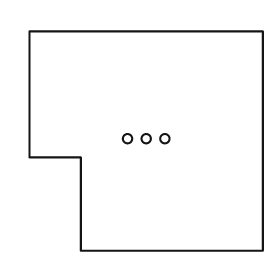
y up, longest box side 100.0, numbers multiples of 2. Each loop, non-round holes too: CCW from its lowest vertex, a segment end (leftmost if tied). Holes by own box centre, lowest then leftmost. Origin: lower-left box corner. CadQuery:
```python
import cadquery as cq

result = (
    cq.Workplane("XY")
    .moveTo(22.0, 0.0)
    .lineTo(100.0, 0.0)
    .lineTo(100.0, 94.0)
    .lineTo(0.0, 94.0)
    .lineTo(0.0, 40.0)
    .lineTo(22.0, 40.0)
    .close()
    .moveTo(42.0, 48.0)
    .circle(2.0)
    .moveTo(50.0, 48.0)
    .circle(2.0)
    .moveTo(58.0, 48.0)
    .circle(2.0)
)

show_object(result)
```